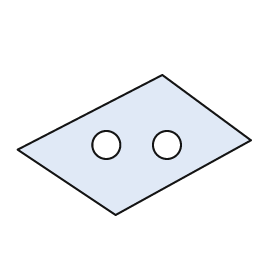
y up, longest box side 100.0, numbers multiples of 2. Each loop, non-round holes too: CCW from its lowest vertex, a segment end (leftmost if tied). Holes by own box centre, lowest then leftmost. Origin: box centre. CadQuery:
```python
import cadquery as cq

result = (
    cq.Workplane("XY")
    .moveTo(-8.0, -30.0)
    .lineTo(50.0, 2.0)
    .lineTo(12.0, 30.0)
    .lineTo(-50.0, -2.0)
    .close()
    .moveTo(-12.0, 0.0)
    .circle(6.0)
    .moveTo(14.0, 0.0)
    .circle(6.0)
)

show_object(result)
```